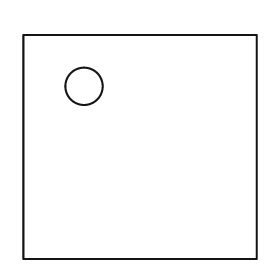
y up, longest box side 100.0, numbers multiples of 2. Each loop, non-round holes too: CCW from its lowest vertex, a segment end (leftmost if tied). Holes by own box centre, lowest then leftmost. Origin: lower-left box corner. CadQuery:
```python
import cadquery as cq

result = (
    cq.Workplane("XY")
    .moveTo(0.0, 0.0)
    .lineTo(100.0, 0.0)
    .lineTo(100.0, 96.0)
    .lineTo(0.0, 96.0)
    .close()
    .moveTo(26.0, 74.0)
    .circle(8.0)
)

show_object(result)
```